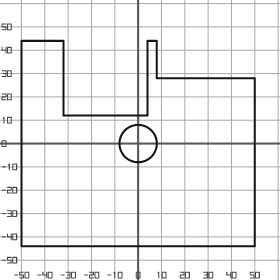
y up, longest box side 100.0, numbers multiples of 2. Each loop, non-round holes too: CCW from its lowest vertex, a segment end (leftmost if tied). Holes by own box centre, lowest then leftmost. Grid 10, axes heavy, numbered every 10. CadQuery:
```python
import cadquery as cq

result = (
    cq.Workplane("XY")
    .moveTo(-50.0, -44.0)
    .lineTo(50.0, -44.0)
    .lineTo(50.0, 28.0)
    .lineTo(8.0, 28.0)
    .lineTo(8.0, 44.0)
    .lineTo(4.0, 44.0)
    .lineTo(4.0, 12.0)
    .lineTo(-32.0, 12.0)
    .lineTo(-32.0, 44.0)
    .lineTo(-50.0, 44.0)
    .close()
    .moveTo(0.0, 0.0)
    .circle(8.0)
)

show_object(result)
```